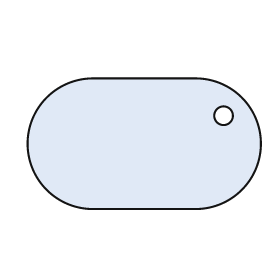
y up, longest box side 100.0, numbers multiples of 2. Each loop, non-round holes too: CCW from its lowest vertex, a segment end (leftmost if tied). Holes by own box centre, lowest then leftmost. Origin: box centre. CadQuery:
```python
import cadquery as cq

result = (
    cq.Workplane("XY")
    .moveTo(-22.0, -28.0)
    .lineTo(22.0, -28.0)
    .threePointArc((50.0, 0.0), (22.0, 28.0))
    .lineTo(-22.0, 28.0)
    .threePointArc((-50.0, 0.0), (-22.0, -28.0))
    .close()
    .moveTo(34.0, 12.0)
    .circle(4.0)
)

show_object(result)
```